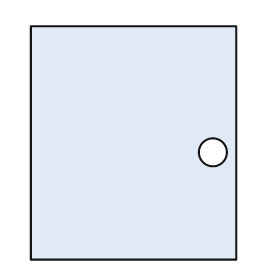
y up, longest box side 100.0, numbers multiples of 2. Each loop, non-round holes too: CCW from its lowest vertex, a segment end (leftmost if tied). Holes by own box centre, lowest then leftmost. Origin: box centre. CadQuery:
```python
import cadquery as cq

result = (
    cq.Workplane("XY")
    .moveTo(-44.0, -50.0)
    .lineTo(44.0, -50.0)
    .lineTo(44.0, 50.0)
    .lineTo(-44.0, 50.0)
    .close()
    .moveTo(34.0, -4.0)
    .circle(6.0)
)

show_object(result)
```